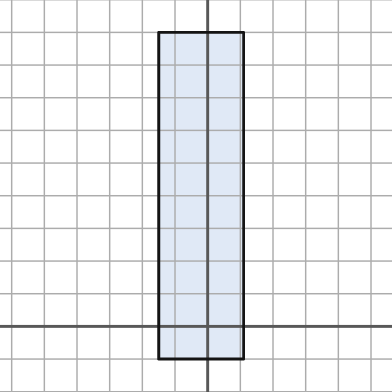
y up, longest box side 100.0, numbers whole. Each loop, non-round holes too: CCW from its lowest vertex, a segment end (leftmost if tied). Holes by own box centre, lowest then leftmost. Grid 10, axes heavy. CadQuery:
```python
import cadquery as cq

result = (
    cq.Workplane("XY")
    .moveTo(-15.0, -10.0)
    .lineTo(11.0, -10.0)
    .lineTo(11.0, 90.0)
    .lineTo(-15.0, 90.0)
    .close()
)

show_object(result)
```